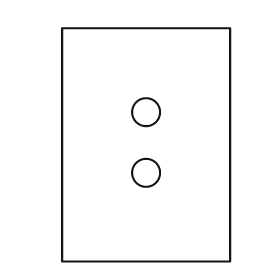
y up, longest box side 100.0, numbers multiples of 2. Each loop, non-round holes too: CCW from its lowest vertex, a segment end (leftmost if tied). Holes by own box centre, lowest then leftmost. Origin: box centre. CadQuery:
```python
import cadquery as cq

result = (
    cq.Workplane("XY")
    .moveTo(-36.0, -50.0)
    .lineTo(36.0, -50.0)
    .lineTo(36.0, 50.0)
    .lineTo(-36.0, 50.0)
    .close()
    .moveTo(0.0, -12.0)
    .circle(6.0)
    .moveTo(0.0, 14.0)
    .circle(6.0)
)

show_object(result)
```